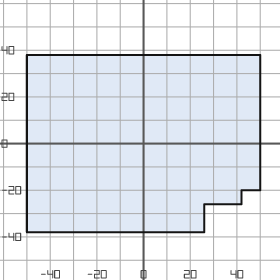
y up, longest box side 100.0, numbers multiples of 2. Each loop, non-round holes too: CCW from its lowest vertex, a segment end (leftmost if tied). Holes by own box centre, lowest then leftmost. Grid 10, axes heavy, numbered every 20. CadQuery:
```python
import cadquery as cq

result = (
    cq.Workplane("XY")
    .moveTo(-50.0, -38.0)
    .lineTo(26.0, -38.0)
    .lineTo(26.0, -26.0)
    .lineTo(42.0, -26.0)
    .lineTo(42.0, -20.0)
    .lineTo(50.0, -20.0)
    .lineTo(50.0, 38.0)
    .lineTo(-50.0, 38.0)
    .close()
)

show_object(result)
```